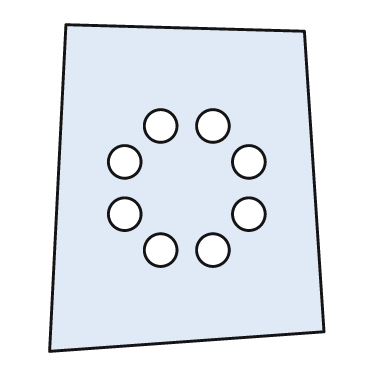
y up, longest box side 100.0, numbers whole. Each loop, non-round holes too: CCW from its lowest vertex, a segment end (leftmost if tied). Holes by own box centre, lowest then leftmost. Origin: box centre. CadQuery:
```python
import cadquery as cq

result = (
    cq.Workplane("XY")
    .moveTo(-42.0, -50.0)
    .lineTo(42.0, -44.0)
    .lineTo(36.0, 48.0)
    .lineTo(-37.0, 50.0)
    .close()
    .moveTo(-8.0, -19.0)
    .circle(5.0)
    .moveTo(8.0, -19.0)
    .circle(5.0)
    .moveTo(-19.0, -8.0)
    .circle(5.0)
    .moveTo(19.0, -8.0)
    .circle(5.0)
    .moveTo(-19.0, 8.0)
    .circle(5.0)
    .moveTo(19.0, 8.0)
    .circle(5.0)
    .moveTo(-8.0, 19.0)
    .circle(5.0)
    .moveTo(8.0, 19.0)
    .circle(5.0)
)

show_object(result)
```